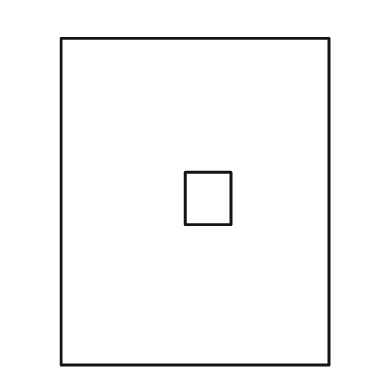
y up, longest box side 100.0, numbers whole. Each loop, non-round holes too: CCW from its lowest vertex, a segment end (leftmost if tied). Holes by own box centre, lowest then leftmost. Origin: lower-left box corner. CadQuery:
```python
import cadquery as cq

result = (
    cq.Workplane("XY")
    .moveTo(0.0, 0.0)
    .lineTo(82.0, 0.0)
    .lineTo(82.0, 100.0)
    .lineTo(0.0, 100.0)
    .close()
    .moveTo(38.0, 43.0)
    .lineTo(52.0, 43.0)
    .lineTo(52.0, 59.0)
    .lineTo(38.0, 59.0)
    .close()
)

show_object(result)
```